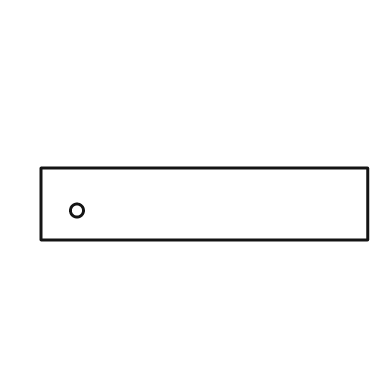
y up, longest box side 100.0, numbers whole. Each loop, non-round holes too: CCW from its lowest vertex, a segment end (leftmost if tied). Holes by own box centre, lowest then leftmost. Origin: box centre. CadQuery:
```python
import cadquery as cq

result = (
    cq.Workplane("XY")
    .moveTo(-50.0, -11.0)
    .lineTo(50.0, -11.0)
    .lineTo(50.0, 11.0)
    .lineTo(-50.0, 11.0)
    .close()
    .moveTo(-39.0, -2.0)
    .circle(2.0)
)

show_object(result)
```